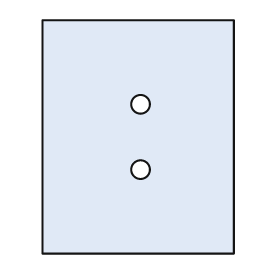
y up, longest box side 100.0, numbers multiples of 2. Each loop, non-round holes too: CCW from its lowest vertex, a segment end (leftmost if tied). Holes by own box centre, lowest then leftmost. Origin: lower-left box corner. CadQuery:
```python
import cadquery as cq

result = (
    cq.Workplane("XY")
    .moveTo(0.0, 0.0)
    .lineTo(82.0, 0.0)
    .lineTo(82.0, 100.0)
    .lineTo(0.0, 100.0)
    .close()
    .moveTo(42.0, 36.0)
    .circle(4.0)
    .moveTo(42.0, 64.0)
    .circle(4.0)
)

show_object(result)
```